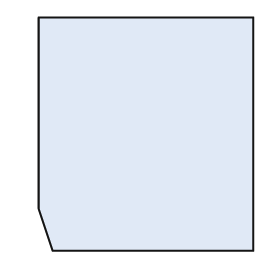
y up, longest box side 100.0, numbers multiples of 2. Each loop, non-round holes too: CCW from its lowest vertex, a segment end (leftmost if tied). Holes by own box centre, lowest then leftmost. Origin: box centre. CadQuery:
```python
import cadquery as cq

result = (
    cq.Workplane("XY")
    .moveTo(-40.0, -50.0)
    .lineTo(46.0, -50.0)
    .lineTo(46.0, 50.0)
    .lineTo(-46.0, 50.0)
    .lineTo(-46.0, -32.0)
    .close()
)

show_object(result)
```